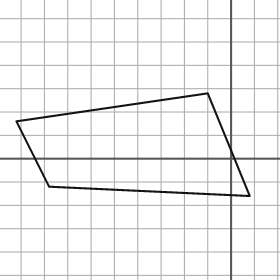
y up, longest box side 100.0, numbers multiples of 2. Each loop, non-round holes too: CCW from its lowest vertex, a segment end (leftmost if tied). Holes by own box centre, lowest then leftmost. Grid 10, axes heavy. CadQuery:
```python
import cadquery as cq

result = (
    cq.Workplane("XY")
    .moveTo(8.0, -16.0)
    .lineTo(-10.0, 28.0)
    .lineTo(-92.0, 16.0)
    .lineTo(-78.0, -12.0)
    .close()
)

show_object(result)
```